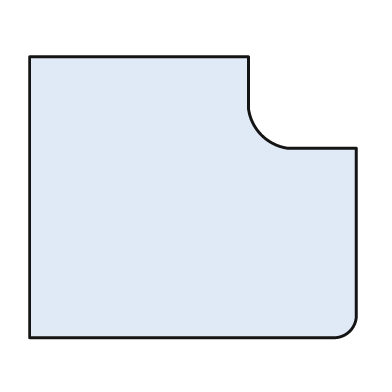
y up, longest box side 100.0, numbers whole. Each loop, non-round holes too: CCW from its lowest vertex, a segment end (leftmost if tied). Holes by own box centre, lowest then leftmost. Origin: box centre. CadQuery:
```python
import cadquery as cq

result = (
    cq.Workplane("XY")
    .moveTo(-50.0, -43.0)
    .lineTo(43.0, -43.0)
    .threePointArc((48.0, -41.0), (50.0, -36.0))
    .lineTo(50.0, 15.0)
    .lineTo(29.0, 15.0)
    .threePointArc((21.0, 19.0), (17.0, 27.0))
    .lineTo(17.0, 43.0)
    .lineTo(-50.0, 43.0)
    .close()
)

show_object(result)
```